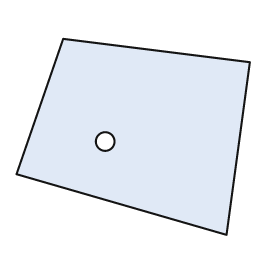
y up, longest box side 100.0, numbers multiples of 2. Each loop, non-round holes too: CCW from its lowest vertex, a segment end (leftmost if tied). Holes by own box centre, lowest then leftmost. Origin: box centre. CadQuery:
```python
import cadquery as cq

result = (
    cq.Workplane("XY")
    .moveTo(40.0, -42.0)
    .lineTo(50.0, 32.0)
    .lineTo(-30.0, 42.0)
    .lineTo(-50.0, -16.0)
    .close()
    .moveTo(-12.0, -2.0)
    .circle(4.0)
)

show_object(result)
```